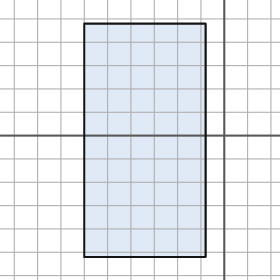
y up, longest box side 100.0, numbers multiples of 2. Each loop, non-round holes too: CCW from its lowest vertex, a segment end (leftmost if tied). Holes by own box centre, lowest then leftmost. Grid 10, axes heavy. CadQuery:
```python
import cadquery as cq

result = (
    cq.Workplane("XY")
    .moveTo(-60.0, -52.0)
    .lineTo(-8.0, -52.0)
    .lineTo(-8.0, 48.0)
    .lineTo(-60.0, 48.0)
    .close()
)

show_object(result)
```